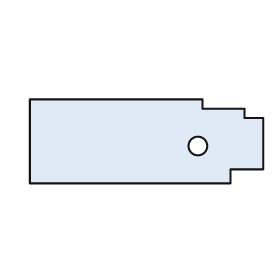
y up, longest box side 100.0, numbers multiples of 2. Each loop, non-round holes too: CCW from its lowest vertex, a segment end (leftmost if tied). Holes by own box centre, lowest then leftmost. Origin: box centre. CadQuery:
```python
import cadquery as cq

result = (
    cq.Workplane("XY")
    .moveTo(-50.0, -18.0)
    .lineTo(36.0, -18.0)
    .lineTo(36.0, -12.0)
    .lineTo(50.0, -12.0)
    .lineTo(50.0, 10.0)
    .lineTo(42.0, 10.0)
    .lineTo(42.0, 14.0)
    .lineTo(24.0, 14.0)
    .lineTo(24.0, 18.0)
    .lineTo(-50.0, 18.0)
    .close()
    .moveTo(22.0, -2.0)
    .circle(4.0)
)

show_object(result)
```